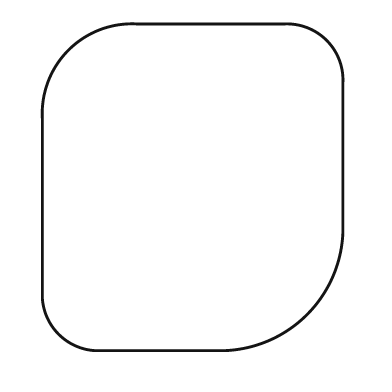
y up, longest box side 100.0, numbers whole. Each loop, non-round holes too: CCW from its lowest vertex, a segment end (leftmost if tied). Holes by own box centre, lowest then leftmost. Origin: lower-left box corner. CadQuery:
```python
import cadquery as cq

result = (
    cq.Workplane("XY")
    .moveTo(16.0, 0.0)
    .lineTo(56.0, 0.0)
    .threePointArc((81.0, 11.0), (92.0, 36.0))
    .lineTo(92.0, 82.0)
    .threePointArc((87.0, 95.0), (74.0, 100.0))
    .lineTo(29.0, 100.0)
    .threePointArc((8.0, 92.0), (0.0, 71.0))
    .lineTo(0.0, 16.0)
    .threePointArc((5.0, 5.0), (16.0, 0.0))
    .close()
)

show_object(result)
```